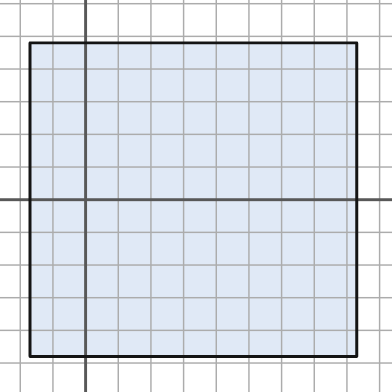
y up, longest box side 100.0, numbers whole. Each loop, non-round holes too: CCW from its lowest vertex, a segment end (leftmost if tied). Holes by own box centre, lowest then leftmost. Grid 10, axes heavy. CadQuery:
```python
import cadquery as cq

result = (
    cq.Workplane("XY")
    .moveTo(-17.0, -48.0)
    .lineTo(83.0, -48.0)
    .lineTo(83.0, 48.0)
    .lineTo(-17.0, 48.0)
    .close()
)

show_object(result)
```